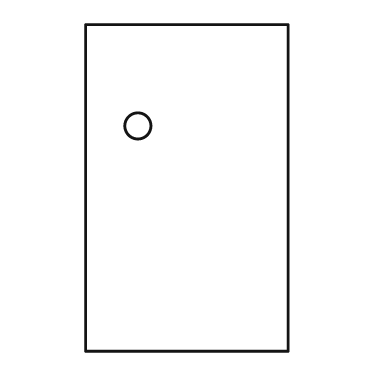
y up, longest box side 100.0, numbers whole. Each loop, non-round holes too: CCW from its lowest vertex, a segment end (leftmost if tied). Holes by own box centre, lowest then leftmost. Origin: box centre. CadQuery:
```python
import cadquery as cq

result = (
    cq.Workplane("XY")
    .moveTo(-31.0, -50.0)
    .lineTo(31.0, -50.0)
    .lineTo(31.0, 50.0)
    .lineTo(-31.0, 50.0)
    .close()
    .moveTo(-15.0, 19.0)
    .circle(4.0)
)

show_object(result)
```